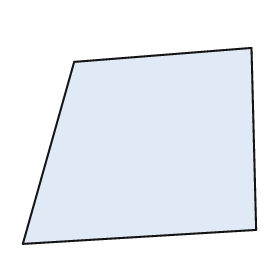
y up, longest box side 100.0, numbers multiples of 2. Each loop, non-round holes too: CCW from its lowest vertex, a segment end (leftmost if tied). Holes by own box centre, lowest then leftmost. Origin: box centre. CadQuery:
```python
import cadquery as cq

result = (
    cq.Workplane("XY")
    .moveTo(-50.0, -42.0)
    .lineTo(50.0, -36.0)
    .lineTo(48.0, 42.0)
    .lineTo(-28.0, 36.0)
    .close()
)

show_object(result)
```